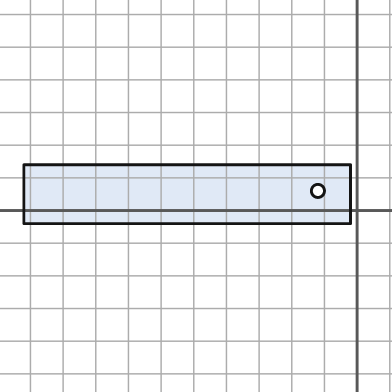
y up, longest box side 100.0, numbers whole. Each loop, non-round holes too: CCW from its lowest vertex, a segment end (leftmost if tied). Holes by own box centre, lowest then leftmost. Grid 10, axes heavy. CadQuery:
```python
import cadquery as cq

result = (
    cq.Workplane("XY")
    .moveTo(-102.0, -4.0)
    .lineTo(-2.0, -4.0)
    .lineTo(-2.0, 14.0)
    .lineTo(-102.0, 14.0)
    .close()
    .moveTo(-12.0, 6.0)
    .circle(2.0)
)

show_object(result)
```